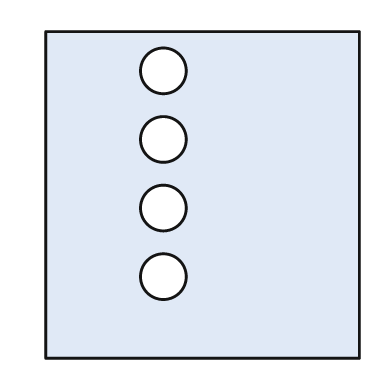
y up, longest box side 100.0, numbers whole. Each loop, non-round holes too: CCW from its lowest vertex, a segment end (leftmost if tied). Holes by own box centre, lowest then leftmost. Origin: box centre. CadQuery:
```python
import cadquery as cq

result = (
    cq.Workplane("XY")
    .moveTo(-48.0, -50.0)
    .lineTo(48.0, -50.0)
    .lineTo(48.0, 50.0)
    .lineTo(-48.0, 50.0)
    .close()
    .moveTo(-12.0, -25.0)
    .circle(7.0)
    .moveTo(-12.0, -4.0)
    .circle(7.0)
    .moveTo(-12.0, 17.0)
    .circle(7.0)
    .moveTo(-12.0, 38.0)
    .circle(7.0)
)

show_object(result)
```